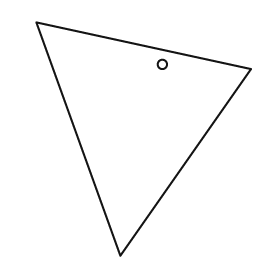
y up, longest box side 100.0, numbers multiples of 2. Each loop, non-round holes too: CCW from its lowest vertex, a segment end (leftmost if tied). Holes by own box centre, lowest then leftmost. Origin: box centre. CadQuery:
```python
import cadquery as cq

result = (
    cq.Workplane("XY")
    .moveTo(-10.0, -50.0)
    .lineTo(46.0, 30.0)
    .lineTo(-46.0, 50.0)
    .close()
    .moveTo(8.0, 32.0)
    .circle(2.0)
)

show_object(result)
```